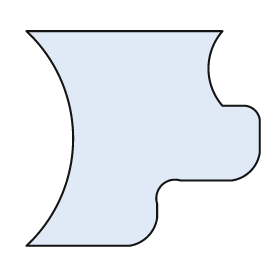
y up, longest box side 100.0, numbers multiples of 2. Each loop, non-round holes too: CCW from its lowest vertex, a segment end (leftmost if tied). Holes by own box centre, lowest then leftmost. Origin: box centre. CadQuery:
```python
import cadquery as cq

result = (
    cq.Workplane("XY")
    .moveTo(-50.0, -46.0)
    .lineTo(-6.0, -46.0)
    .threePointArc((2.0, -42.0), (6.0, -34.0))
    .lineTo(6.0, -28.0)
    .threePointArc((8.0, -20.0), (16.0, -18.0))
    .lineTo(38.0, -18.0)
    .threePointArc((46.0, -14.0), (50.0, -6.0))
    .lineTo(50.0, 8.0)
    .threePointArc((48.0, 12.0), (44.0, 14.0))
    .lineTo(34.0, 14.0)
    .threePointArc((28.0, 30.0), (34.0, 46.0))
    .lineTo(-50.0, 46.0)
    .threePointArc((-30.0, 0.0), (-50.0, -46.0))
    .close()
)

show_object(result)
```